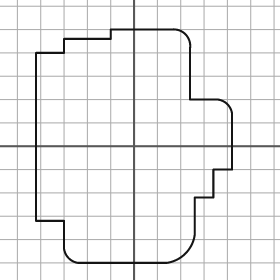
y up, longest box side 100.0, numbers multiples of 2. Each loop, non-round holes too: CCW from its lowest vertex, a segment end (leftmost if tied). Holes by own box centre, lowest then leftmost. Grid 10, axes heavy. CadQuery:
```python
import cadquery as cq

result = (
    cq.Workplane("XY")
    .moveTo(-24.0, -50.0)
    .lineTo(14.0, -50.0)
    .threePointArc((22.0, -46.0), (26.0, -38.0))
    .lineTo(26.0, -22.0)
    .lineTo(34.0, -22.0)
    .lineTo(34.0, -10.0)
    .lineTo(42.0, -10.0)
    .lineTo(42.0, 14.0)
    .threePointArc((40.0, 18.0), (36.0, 20.0))
    .lineTo(24.0, 20.0)
    .lineTo(24.0, 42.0)
    .threePointArc((22.0, 48.0), (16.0, 50.0))
    .lineTo(-10.0, 50.0)
    .lineTo(-10.0, 46.0)
    .lineTo(-30.0, 46.0)
    .lineTo(-30.0, 40.0)
    .lineTo(-42.0, 40.0)
    .lineTo(-42.0, -32.0)
    .lineTo(-30.0, -32.0)
    .lineTo(-30.0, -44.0)
    .threePointArc((-28.0, -48.0), (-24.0, -50.0))
    .close()
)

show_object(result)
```